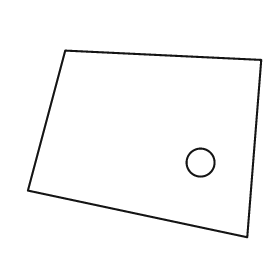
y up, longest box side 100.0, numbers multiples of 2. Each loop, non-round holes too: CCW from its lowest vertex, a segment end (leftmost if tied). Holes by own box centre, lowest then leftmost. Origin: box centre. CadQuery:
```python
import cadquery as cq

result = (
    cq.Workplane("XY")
    .moveTo(44.0, -40.0)
    .lineTo(50.0, 36.0)
    .lineTo(-34.0, 40.0)
    .lineTo(-50.0, -20.0)
    .close()
    .moveTo(24.0, -8.0)
    .circle(6.0)
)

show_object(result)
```